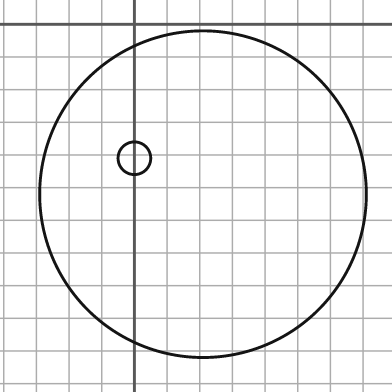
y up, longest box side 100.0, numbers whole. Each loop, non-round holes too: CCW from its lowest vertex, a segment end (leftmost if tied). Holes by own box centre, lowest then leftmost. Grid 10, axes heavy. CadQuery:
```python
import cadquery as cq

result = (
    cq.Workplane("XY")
    .moveTo(21.0, -52.0)
    .circle(50.0)
    .moveTo(0.0, -41.0)
    .circle(5.0)
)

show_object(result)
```